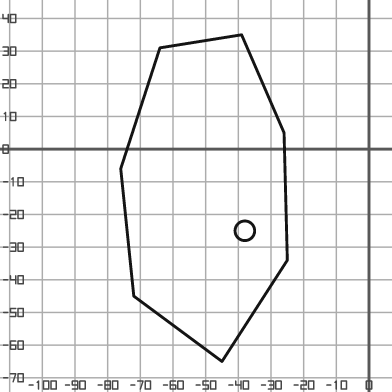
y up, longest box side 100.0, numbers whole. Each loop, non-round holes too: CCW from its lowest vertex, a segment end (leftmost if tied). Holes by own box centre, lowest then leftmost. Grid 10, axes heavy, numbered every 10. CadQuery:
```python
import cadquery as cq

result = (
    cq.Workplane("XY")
    .moveTo(-45.0, -65.0)
    .lineTo(-25.0, -34.0)
    .lineTo(-26.0, 5.0)
    .lineTo(-39.0, 35.0)
    .lineTo(-64.0, 31.0)
    .lineTo(-76.0, -6.0)
    .lineTo(-72.0, -45.0)
    .close()
    .moveTo(-38.0, -25.0)
    .circle(3.0)
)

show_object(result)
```